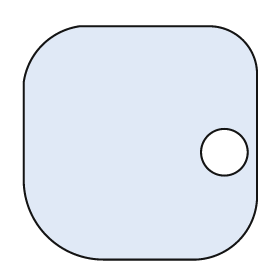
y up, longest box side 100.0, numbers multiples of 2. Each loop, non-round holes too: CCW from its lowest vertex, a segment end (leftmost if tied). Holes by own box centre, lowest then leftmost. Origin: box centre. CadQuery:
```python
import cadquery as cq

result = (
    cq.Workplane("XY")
    .moveTo(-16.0, -50.0)
    .lineTo(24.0, -50.0)
    .threePointArc((42.0, -42.0), (50.0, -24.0))
    .lineTo(50.0, 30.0)
    .threePointArc((44.0, 44.0), (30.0, 50.0))
    .lineTo(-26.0, 50.0)
    .threePointArc((-42.0, 42.0), (-50.0, 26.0))
    .lineTo(-50.0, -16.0)
    .threePointArc((-40.0, -40.0), (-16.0, -50.0))
    .close()
    .moveTo(36.0, -4.0)
    .circle(10.0)
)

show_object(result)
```